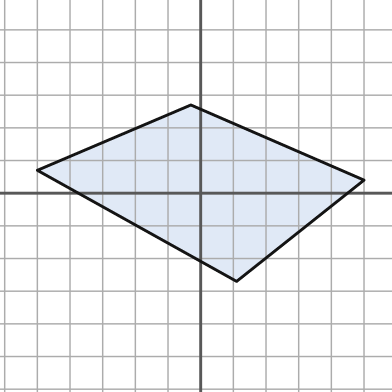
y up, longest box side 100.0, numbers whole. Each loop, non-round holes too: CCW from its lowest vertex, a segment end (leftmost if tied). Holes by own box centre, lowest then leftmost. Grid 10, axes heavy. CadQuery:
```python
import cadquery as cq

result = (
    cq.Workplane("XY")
    .moveTo(11.0, -27.0)
    .lineTo(50.0, 4.0)
    .lineTo(-3.0, 27.0)
    .lineTo(-50.0, 7.0)
    .close()
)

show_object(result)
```